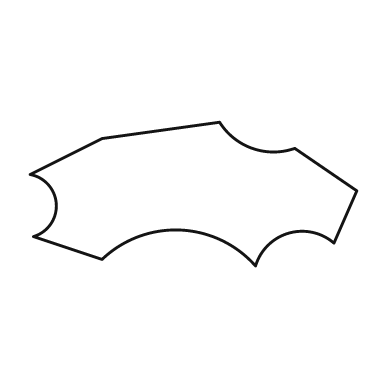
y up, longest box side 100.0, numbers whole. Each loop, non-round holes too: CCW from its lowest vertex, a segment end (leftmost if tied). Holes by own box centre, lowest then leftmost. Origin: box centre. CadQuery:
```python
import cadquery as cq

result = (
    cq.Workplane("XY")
    .moveTo(19.0, -22.0)
    .threePointArc((29.0, -12.0), (43.0, -15.0))
    .lineTo(50.0, 1.0)
    .lineTo(31.0, 14.0)
    .threePointArc((18.0, 14.0), (8.0, 22.0))
    .lineTo(-28.0, 17.0)
    .lineTo(-50.0, 6.0)
    .threePointArc((-42.0, -3.0), (-49.0, -13.0))
    .lineTo(-28.0, -20.0)
    .threePointArc((-4.0, -11.0), (19.0, -22.0))
    .close()
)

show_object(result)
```